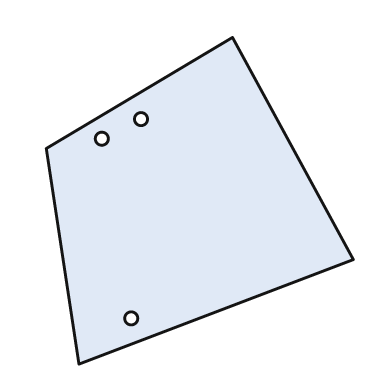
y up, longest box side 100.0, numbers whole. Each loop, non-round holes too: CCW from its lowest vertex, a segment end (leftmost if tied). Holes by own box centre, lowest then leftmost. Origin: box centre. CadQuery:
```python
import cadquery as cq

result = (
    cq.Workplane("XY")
    .moveTo(-37.0, -50.0)
    .lineTo(47.0, -18.0)
    .lineTo(10.0, 50.0)
    .lineTo(-47.0, 16.0)
    .close()
    .moveTo(-21.0, -36.0)
    .circle(2.0)
    .moveTo(-30.0, 19.0)
    .circle(2.0)
    .moveTo(-18.0, 25.0)
    .circle(2.0)
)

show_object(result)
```